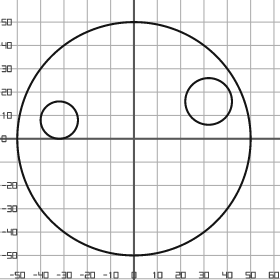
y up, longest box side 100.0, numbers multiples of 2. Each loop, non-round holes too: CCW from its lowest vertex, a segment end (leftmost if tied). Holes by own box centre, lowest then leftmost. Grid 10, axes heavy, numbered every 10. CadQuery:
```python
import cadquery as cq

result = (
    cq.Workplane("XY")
    .moveTo(0.0, 0.0)
    .circle(50.0)
    .moveTo(-32.0, 8.0)
    .circle(8.0)
    .moveTo(32.0, 16.0)
    .circle(10.0)
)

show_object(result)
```